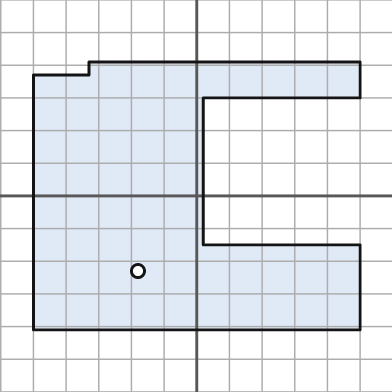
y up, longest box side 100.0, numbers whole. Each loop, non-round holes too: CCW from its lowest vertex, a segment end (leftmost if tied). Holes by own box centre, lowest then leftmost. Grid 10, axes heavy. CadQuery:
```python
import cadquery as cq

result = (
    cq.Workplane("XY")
    .moveTo(-50.0, -41.0)
    .lineTo(50.0, -41.0)
    .lineTo(50.0, -15.0)
    .lineTo(2.0, -15.0)
    .lineTo(2.0, 30.0)
    .lineTo(50.0, 30.0)
    .lineTo(50.0, 41.0)
    .lineTo(-33.0, 41.0)
    .lineTo(-33.0, 37.0)
    .lineTo(-50.0, 37.0)
    .close()
    .moveTo(-18.0, -23.0)
    .circle(2.0)
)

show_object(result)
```